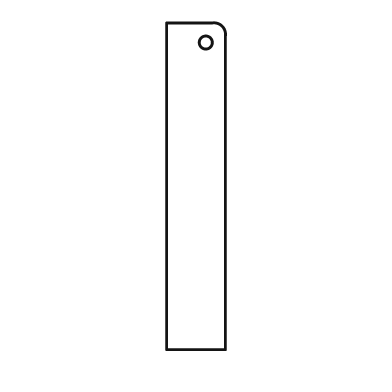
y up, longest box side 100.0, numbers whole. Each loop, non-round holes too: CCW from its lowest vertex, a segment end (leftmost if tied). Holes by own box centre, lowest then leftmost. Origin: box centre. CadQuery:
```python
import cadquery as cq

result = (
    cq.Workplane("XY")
    .moveTo(-9.0, -50.0)
    .lineTo(9.0, -50.0)
    .lineTo(9.0, 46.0)
    .threePointArc((8.0, 49.0), (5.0, 50.0))
    .lineTo(-9.0, 50.0)
    .close()
    .moveTo(3.0, 44.0)
    .circle(2.0)
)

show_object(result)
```